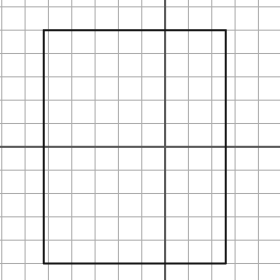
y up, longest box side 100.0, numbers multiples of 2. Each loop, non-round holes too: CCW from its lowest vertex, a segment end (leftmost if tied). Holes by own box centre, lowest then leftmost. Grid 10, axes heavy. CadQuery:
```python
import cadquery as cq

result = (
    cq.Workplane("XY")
    .moveTo(-52.0, -50.0)
    .lineTo(26.0, -50.0)
    .lineTo(26.0, 50.0)
    .lineTo(-52.0, 50.0)
    .close()
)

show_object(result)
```